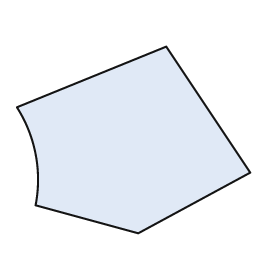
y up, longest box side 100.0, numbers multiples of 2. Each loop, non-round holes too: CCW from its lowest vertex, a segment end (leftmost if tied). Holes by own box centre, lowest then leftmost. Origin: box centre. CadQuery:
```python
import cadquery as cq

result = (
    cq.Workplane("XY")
    .moveTo(2.0, -40.0)
    .lineTo(50.0, -14.0)
    .lineTo(14.0, 40.0)
    .lineTo(-50.0, 14.0)
    .threePointArc((-42.0, -6.0), (-42.0, -28.0))
    .close()
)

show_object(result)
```